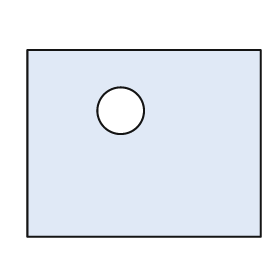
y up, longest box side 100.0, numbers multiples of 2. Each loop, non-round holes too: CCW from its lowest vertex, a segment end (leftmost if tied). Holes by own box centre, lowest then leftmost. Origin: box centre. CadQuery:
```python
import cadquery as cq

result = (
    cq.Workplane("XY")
    .moveTo(-50.0, -40.0)
    .lineTo(50.0, -40.0)
    .lineTo(50.0, 40.0)
    .lineTo(-50.0, 40.0)
    .close()
    .moveTo(-10.0, 14.0)
    .circle(10.0)
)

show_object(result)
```